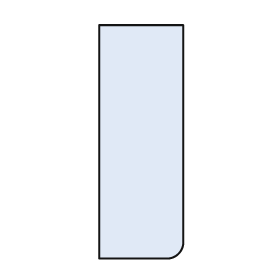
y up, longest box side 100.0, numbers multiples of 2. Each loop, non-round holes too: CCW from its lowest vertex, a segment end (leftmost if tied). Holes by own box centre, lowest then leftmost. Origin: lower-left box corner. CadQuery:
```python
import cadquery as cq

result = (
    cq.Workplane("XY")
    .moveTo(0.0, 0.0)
    .lineTo(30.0, 0.0)
    .threePointArc((34.0, 2.0), (36.0, 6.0))
    .lineTo(36.0, 100.0)
    .lineTo(0.0, 100.0)
    .close()
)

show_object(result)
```